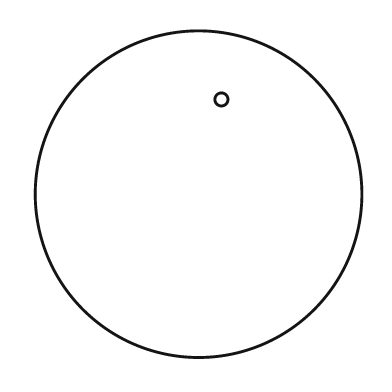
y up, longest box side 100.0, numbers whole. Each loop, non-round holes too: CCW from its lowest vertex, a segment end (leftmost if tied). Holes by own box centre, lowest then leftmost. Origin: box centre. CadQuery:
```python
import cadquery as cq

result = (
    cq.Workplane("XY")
    .moveTo(0.0, 0.0)
    .circle(50.0)
    .moveTo(7.0, 29.0)
    .circle(2.0)
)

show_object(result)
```